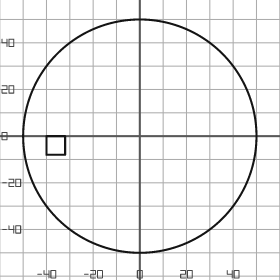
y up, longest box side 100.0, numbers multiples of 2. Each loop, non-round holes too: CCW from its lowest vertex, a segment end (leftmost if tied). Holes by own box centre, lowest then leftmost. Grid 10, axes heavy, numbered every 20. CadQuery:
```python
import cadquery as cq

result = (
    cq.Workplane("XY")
    .moveTo(0.0, 0.0)
    .circle(50.0)
    .moveTo(-40.0, -8.0)
    .lineTo(-32.0, -8.0)
    .lineTo(-32.0, 0.0)
    .lineTo(-40.0, 0.0)
    .close()
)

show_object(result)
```